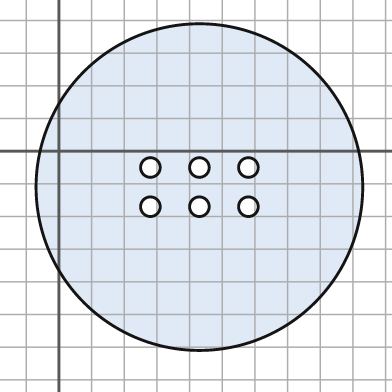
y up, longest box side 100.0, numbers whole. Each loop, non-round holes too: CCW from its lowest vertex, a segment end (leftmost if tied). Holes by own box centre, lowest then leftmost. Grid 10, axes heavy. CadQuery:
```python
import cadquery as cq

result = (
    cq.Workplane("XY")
    .moveTo(43.0, -11.0)
    .circle(50.0)
    .moveTo(28.0, -17.0)
    .circle(3.0)
    .moveTo(43.0, -17.0)
    .circle(3.0)
    .moveTo(58.0, -17.0)
    .circle(3.0)
    .moveTo(28.0, -5.0)
    .circle(3.0)
    .moveTo(43.0, -5.0)
    .circle(3.0)
    .moveTo(58.0, -5.0)
    .circle(3.0)
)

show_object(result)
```